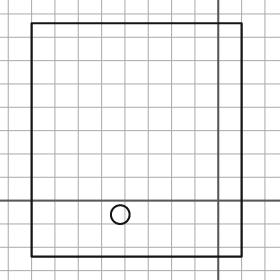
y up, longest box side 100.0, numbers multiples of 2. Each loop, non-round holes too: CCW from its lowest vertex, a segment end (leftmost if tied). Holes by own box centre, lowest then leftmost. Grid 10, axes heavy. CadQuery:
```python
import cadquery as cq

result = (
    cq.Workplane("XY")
    .moveTo(-80.0, -24.0)
    .lineTo(10.0, -24.0)
    .lineTo(10.0, 76.0)
    .lineTo(-80.0, 76.0)
    .close()
    .moveTo(-42.0, -6.0)
    .circle(4.0)
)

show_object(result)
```